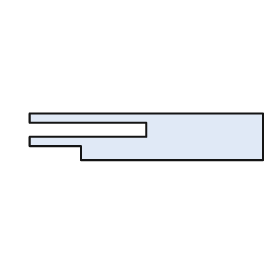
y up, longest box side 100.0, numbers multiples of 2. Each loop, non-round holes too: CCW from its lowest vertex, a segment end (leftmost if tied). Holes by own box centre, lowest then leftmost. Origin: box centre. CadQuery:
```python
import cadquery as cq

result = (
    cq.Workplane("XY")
    .moveTo(-28.0, -10.0)
    .lineTo(50.0, -10.0)
    .lineTo(50.0, 10.0)
    .lineTo(-50.0, 10.0)
    .lineTo(-50.0, 6.0)
    .lineTo(0.0, 6.0)
    .lineTo(0.0, 0.0)
    .lineTo(-50.0, 0.0)
    .lineTo(-50.0, -4.0)
    .lineTo(-28.0, -4.0)
    .close()
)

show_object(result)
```